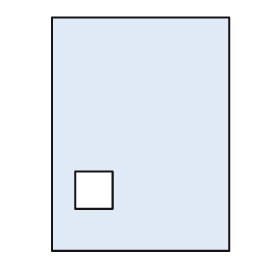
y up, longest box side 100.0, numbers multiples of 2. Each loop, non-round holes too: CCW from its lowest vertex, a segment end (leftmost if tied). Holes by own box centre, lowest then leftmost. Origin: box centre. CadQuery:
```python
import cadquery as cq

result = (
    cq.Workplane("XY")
    .moveTo(-38.0, -50.0)
    .lineTo(38.0, -50.0)
    .lineTo(38.0, 50.0)
    .lineTo(-38.0, 50.0)
    .close()
    .moveTo(-28.0, -32.0)
    .lineTo(-12.0, -32.0)
    .lineTo(-12.0, -16.0)
    .lineTo(-28.0, -16.0)
    .close()
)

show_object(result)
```